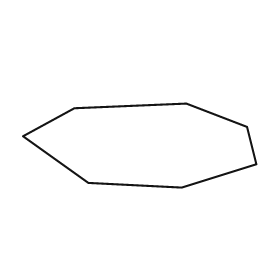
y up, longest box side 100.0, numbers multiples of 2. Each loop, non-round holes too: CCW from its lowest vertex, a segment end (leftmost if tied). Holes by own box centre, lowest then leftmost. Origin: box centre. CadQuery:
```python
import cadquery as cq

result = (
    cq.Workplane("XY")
    .moveTo(18.0, -18.0)
    .lineTo(50.0, -8.0)
    .lineTo(46.0, 8.0)
    .lineTo(20.0, 18.0)
    .lineTo(-28.0, 16.0)
    .lineTo(-50.0, 4.0)
    .lineTo(-22.0, -16.0)
    .close()
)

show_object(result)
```